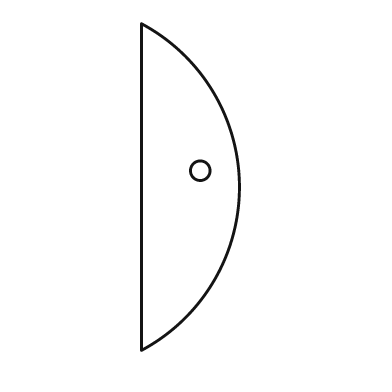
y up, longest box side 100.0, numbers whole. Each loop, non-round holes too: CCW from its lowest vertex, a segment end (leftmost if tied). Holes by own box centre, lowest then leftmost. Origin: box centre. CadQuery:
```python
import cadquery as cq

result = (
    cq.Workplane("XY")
    .moveTo(-15.0, -50.0)
    .threePointArc((15.0, 0.0), (-15.0, 50.0))
    .close()
    .moveTo(3.0, 5.0)
    .circle(3.0)
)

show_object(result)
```